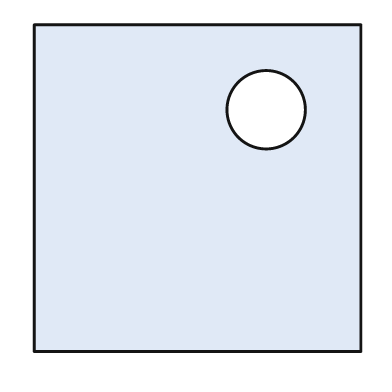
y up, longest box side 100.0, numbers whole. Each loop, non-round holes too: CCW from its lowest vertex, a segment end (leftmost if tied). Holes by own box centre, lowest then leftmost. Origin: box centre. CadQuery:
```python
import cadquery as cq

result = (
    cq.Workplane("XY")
    .moveTo(-50.0, -50.0)
    .lineTo(50.0, -50.0)
    .lineTo(50.0, 50.0)
    .lineTo(-50.0, 50.0)
    .close()
    .moveTo(21.0, 24.0)
    .circle(12.0)
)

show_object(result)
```